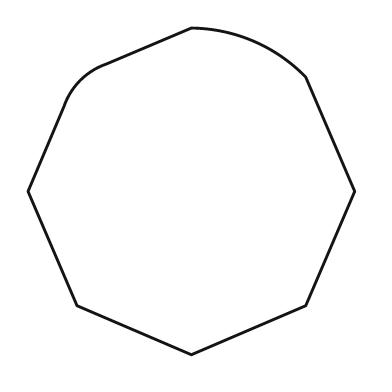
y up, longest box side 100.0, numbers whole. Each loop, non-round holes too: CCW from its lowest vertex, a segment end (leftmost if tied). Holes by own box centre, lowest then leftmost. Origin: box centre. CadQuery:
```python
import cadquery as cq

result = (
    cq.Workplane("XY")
    .moveTo(0.0, -50.0)
    .lineTo(35.0, -35.0)
    .lineTo(50.0, 0.0)
    .lineTo(35.0, 35.0)
    .threePointArc((19.0, 46.0), (0.0, 50.0))
    .lineTo(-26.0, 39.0)
    .threePointArc((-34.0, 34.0), (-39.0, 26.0))
    .lineTo(-50.0, 0.0)
    .lineTo(-35.0, -35.0)
    .close()
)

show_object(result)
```